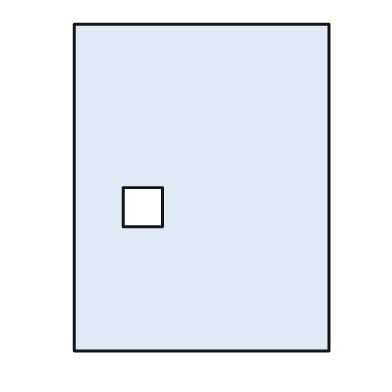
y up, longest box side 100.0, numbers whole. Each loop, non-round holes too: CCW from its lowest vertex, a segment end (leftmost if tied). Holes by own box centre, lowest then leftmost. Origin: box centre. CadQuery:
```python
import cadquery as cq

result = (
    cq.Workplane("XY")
    .moveTo(-39.0, -50.0)
    .lineTo(39.0, -50.0)
    .lineTo(39.0, 50.0)
    .lineTo(-39.0, 50.0)
    .close()
    .moveTo(-24.0, -12.0)
    .lineTo(-12.0, -12.0)
    .lineTo(-12.0, 0.0)
    .lineTo(-24.0, 0.0)
    .close()
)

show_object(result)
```